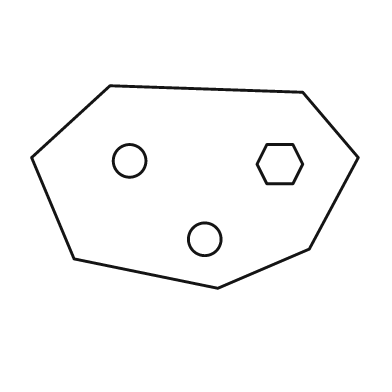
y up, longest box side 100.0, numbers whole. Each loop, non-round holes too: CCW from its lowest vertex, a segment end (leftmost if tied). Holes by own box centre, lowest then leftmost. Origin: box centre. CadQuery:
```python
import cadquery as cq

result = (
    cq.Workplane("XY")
    .moveTo(7.0, -31.0)
    .lineTo(35.0, -19.0)
    .lineTo(50.0, 9.0)
    .lineTo(33.0, 29.0)
    .lineTo(-26.0, 31.0)
    .lineTo(-50.0, 9.0)
    .lineTo(-37.0, -22.0)
    .close()
    .moveTo(3.0, -16.0)
    .circle(5.0)
    .moveTo(22.0, 1.0)
    .lineTo(30.0, 1.0)
    .lineTo(33.0, 7.0)
    .lineTo(30.0, 13.0)
    .lineTo(22.0, 13.0)
    .lineTo(19.0, 7.0)
    .close()
    .moveTo(-20.0, 8.0)
    .circle(5.0)
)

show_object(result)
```